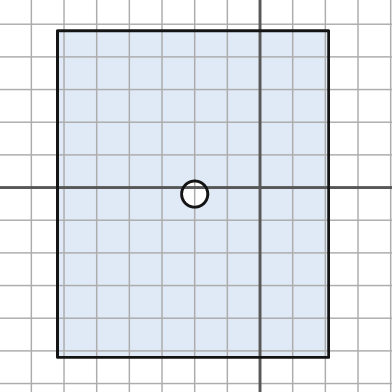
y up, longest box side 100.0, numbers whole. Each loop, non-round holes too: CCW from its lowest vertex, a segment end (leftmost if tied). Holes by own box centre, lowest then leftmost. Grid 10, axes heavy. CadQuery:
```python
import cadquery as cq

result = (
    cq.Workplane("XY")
    .moveTo(-62.0, -52.0)
    .lineTo(21.0, -52.0)
    .lineTo(21.0, 48.0)
    .lineTo(-62.0, 48.0)
    .close()
    .moveTo(-20.0, -2.0)
    .circle(4.0)
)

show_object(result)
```